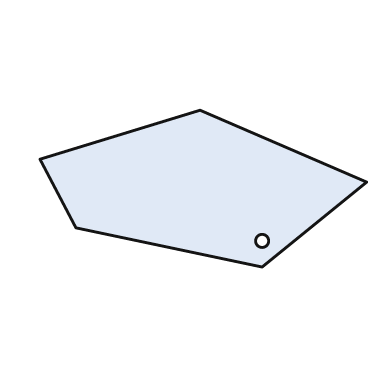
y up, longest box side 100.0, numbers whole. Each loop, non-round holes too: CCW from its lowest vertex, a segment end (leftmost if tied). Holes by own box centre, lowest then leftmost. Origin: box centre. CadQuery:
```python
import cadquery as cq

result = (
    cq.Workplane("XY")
    .moveTo(18.0, -24.0)
    .lineTo(50.0, 2.0)
    .lineTo(-1.0, 24.0)
    .lineTo(-50.0, 9.0)
    .lineTo(-39.0, -12.0)
    .close()
    .moveTo(18.0, -16.0)
    .circle(2.0)
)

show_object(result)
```